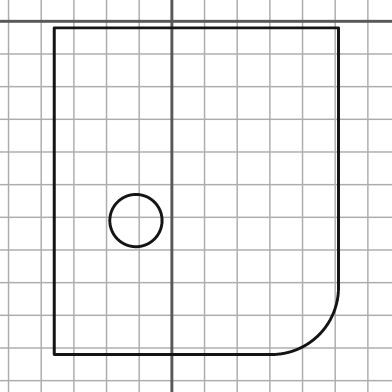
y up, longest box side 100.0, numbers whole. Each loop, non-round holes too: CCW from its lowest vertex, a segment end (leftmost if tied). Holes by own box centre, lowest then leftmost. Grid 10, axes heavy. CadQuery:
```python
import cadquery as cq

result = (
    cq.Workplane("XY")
    .moveTo(-36.0, -102.0)
    .lineTo(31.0, -102.0)
    .threePointArc((45.0, -96.0), (51.0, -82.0))
    .lineTo(51.0, -2.0)
    .lineTo(-36.0, -2.0)
    .close()
    .moveTo(-11.0, -61.0)
    .circle(8.0)
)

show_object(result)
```